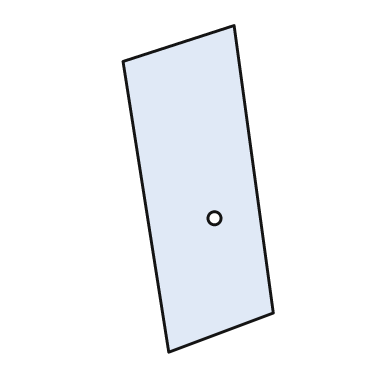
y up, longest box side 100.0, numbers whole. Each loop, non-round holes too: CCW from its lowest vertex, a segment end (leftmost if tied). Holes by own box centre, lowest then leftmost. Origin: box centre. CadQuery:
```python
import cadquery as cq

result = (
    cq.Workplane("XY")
    .moveTo(-9.0, -50.0)
    .lineTo(23.0, -38.0)
    .lineTo(11.0, 50.0)
    .lineTo(-23.0, 39.0)
    .close()
    .moveTo(5.0, -9.0)
    .circle(2.0)
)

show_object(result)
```